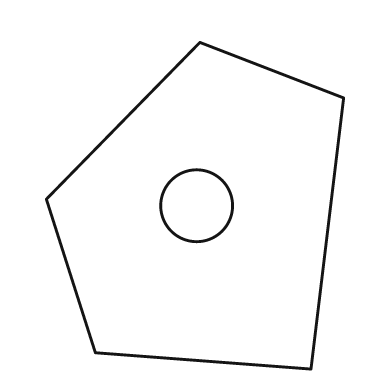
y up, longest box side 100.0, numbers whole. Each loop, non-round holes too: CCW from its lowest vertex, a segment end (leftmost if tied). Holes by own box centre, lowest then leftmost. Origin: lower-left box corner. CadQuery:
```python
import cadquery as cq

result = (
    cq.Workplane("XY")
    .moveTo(81.0, 0.0)
    .lineTo(91.0, 83.0)
    .lineTo(47.0, 100.0)
    .lineTo(0.0, 52.0)
    .lineTo(15.0, 5.0)
    .close()
    .moveTo(46.0, 50.0)
    .circle(11.0)
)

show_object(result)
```